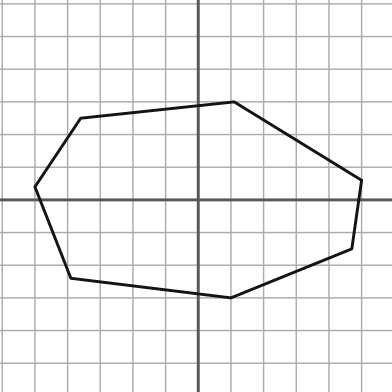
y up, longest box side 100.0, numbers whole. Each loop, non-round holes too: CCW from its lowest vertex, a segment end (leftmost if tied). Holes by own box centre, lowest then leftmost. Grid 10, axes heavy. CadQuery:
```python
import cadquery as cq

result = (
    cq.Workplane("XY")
    .moveTo(10.0, -30.0)
    .lineTo(47.0, -15.0)
    .lineTo(50.0, 6.0)
    .lineTo(11.0, 30.0)
    .lineTo(-36.0, 25.0)
    .lineTo(-50.0, 4.0)
    .lineTo(-39.0, -24.0)
    .close()
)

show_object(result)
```